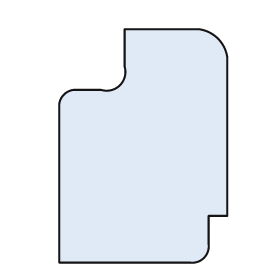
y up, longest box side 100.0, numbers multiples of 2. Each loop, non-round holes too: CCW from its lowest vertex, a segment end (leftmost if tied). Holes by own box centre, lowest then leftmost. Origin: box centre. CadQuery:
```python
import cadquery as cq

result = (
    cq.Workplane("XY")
    .moveTo(-36.0, -50.0)
    .lineTo(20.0, -50.0)
    .threePointArc((26.0, -48.0), (28.0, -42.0))
    .lineTo(28.0, -30.0)
    .lineTo(36.0, -30.0)
    .lineTo(36.0, 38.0)
    .threePointArc((32.0, 46.0), (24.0, 50.0))
    .lineTo(-8.0, 50.0)
    .lineTo(-8.0, 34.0)
    .threePointArc((-10.0, 26.0), (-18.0, 24.0))
    .lineTo(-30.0, 24.0)
    .threePointArc((-34.0, 22.0), (-36.0, 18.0))
    .close()
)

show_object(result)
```